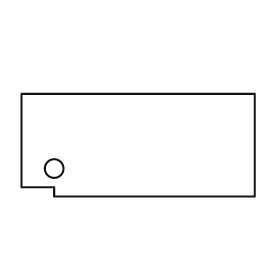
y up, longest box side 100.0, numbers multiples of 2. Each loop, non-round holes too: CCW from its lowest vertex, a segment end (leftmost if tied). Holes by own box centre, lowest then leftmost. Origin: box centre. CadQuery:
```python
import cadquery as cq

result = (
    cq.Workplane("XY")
    .moveTo(-36.0, -22.0)
    .lineTo(50.0, -22.0)
    .lineTo(50.0, 22.0)
    .lineTo(-50.0, 22.0)
    .lineTo(-50.0, -18.0)
    .lineTo(-36.0, -18.0)
    .close()
    .moveTo(-36.0, -10.0)
    .circle(4.0)
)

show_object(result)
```